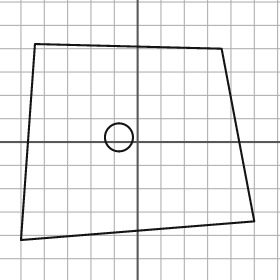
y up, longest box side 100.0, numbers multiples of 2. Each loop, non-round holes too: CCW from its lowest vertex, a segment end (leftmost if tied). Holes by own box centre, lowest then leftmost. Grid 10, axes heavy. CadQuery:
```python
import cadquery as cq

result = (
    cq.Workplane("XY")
    .moveTo(-50.0, -42.0)
    .lineTo(50.0, -34.0)
    .lineTo(36.0, 40.0)
    .lineTo(-44.0, 42.0)
    .close()
    .moveTo(-8.0, 2.0)
    .circle(6.0)
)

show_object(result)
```